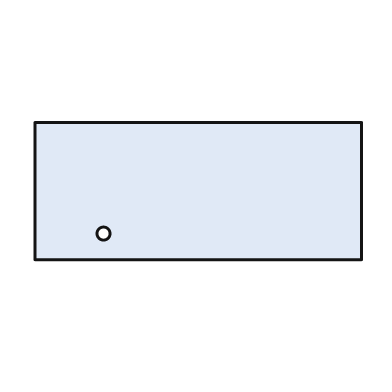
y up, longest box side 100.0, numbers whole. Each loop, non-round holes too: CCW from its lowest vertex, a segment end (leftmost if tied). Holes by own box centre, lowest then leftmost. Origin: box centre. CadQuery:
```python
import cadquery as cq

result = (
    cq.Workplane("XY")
    .moveTo(-50.0, -21.0)
    .lineTo(50.0, -21.0)
    .lineTo(50.0, 21.0)
    .lineTo(-50.0, 21.0)
    .close()
    .moveTo(-29.0, -13.0)
    .circle(2.0)
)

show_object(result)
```